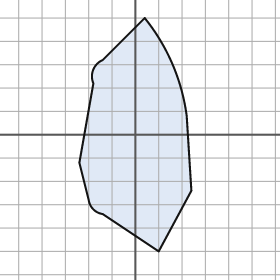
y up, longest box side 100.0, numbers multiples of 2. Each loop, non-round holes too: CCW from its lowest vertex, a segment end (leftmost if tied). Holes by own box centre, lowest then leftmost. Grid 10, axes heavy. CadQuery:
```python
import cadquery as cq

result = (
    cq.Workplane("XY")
    .moveTo(10.0, -50.0)
    .lineTo(24.0, -24.0)
    .lineTo(22.0, 8.0)
    .threePointArc((16.0, 30.0), (4.0, 50.0))
    .lineTo(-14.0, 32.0)
    .threePointArc((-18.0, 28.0), (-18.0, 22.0))
    .lineTo(-24.0, -12.0)
    .lineTo(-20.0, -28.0)
    .threePointArc((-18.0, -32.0), (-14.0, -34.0))
    .close()
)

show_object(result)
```